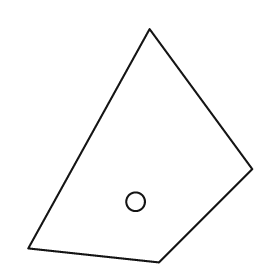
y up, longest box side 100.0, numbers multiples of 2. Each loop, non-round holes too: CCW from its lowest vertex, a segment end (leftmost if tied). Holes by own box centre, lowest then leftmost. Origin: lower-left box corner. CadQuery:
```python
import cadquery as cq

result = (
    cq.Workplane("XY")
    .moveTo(56.0, 0.0)
    .lineTo(96.0, 40.0)
    .lineTo(52.0, 100.0)
    .lineTo(0.0, 6.0)
    .close()
    .moveTo(46.0, 26.0)
    .circle(4.0)
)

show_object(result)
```